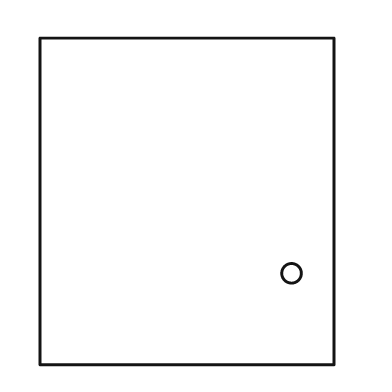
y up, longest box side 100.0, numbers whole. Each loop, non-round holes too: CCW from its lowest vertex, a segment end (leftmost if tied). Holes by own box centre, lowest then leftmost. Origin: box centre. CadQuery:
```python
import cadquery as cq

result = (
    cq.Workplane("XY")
    .moveTo(-45.0, -50.0)
    .lineTo(45.0, -50.0)
    .lineTo(45.0, 50.0)
    .lineTo(-45.0, 50.0)
    .close()
    .moveTo(32.0, -22.0)
    .circle(3.0)
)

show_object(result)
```